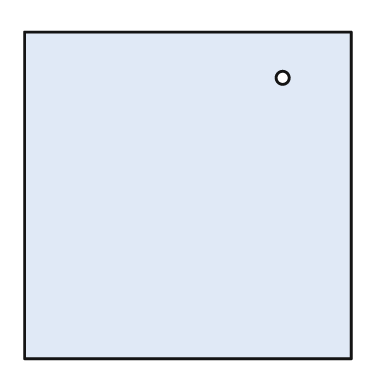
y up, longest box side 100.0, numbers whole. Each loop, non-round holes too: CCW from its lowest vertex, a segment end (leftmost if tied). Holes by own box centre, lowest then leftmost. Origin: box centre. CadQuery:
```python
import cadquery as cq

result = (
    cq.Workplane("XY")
    .moveTo(-50.0, -50.0)
    .lineTo(50.0, -50.0)
    .lineTo(50.0, 50.0)
    .lineTo(-50.0, 50.0)
    .close()
    .moveTo(29.0, 36.0)
    .circle(2.0)
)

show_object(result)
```